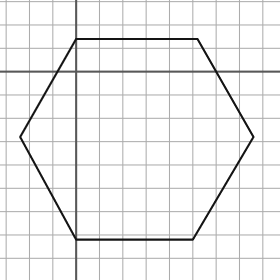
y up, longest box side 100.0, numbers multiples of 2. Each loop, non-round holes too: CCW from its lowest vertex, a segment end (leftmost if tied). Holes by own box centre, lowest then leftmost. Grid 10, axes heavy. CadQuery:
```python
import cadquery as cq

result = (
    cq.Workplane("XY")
    .moveTo(0.0, -72.0)
    .lineTo(50.0, -72.0)
    .lineTo(76.0, -28.0)
    .lineTo(52.0, 14.0)
    .lineTo(0.0, 14.0)
    .lineTo(-24.0, -28.0)
    .close()
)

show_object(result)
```